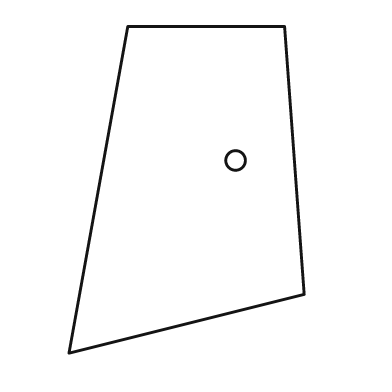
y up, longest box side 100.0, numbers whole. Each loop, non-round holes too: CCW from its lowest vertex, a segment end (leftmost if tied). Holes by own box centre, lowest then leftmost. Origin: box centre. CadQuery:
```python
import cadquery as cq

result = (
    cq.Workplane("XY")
    .moveTo(-36.0, -50.0)
    .lineTo(36.0, -32.0)
    .lineTo(30.0, 50.0)
    .lineTo(-18.0, 50.0)
    .close()
    .moveTo(15.0, 9.0)
    .circle(3.0)
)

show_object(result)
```